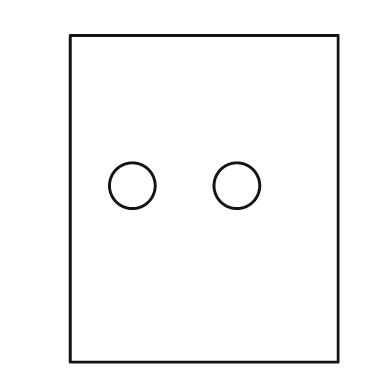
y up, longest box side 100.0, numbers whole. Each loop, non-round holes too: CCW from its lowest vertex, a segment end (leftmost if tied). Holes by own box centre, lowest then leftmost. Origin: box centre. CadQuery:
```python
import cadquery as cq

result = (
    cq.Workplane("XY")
    .moveTo(-41.0, -50.0)
    .lineTo(41.0, -50.0)
    .lineTo(41.0, 50.0)
    .lineTo(-41.0, 50.0)
    .close()
    .moveTo(-22.0, 4.0)
    .circle(7.0)
    .moveTo(10.0, 4.0)
    .circle(7.0)
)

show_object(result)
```